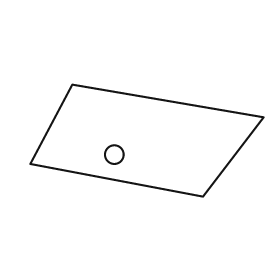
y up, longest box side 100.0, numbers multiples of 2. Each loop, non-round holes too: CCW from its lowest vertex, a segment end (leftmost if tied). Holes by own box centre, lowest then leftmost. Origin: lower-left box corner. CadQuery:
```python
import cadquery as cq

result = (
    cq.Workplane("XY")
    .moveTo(74.0, 0.0)
    .lineTo(100.0, 34.0)
    .lineTo(18.0, 48.0)
    .lineTo(0.0, 14.0)
    .close()
    .moveTo(36.0, 18.0)
    .circle(4.0)
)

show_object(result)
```